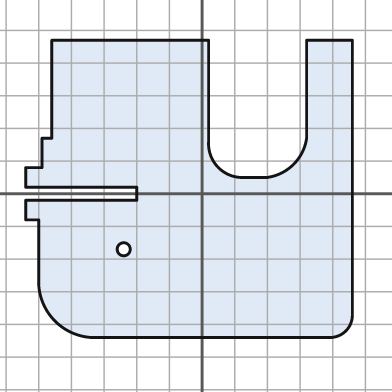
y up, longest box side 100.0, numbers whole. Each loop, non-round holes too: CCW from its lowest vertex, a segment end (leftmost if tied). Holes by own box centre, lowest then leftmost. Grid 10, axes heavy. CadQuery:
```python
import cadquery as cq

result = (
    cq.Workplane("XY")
    .moveTo(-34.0, -44.0)
    .lineTo(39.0, -44.0)
    .threePointArc((44.0, -42.0), (46.0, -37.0))
    .lineTo(46.0, 47.0)
    .lineTo(32.0, 47.0)
    .lineTo(32.0, 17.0)
    .threePointArc((28.0, 9.0), (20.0, 5.0))
    .lineTo(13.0, 5.0)
    .threePointArc((5.0, 8.0), (2.0, 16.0))
    .lineTo(2.0, 47.0)
    .lineTo(-46.0, 47.0)
    .lineTo(-46.0, 17.0)
    .lineTo(-49.0, 17.0)
    .lineTo(-49.0, 8.0)
    .lineTo(-54.0, 8.0)
    .lineTo(-54.0, 2.0)
    .lineTo(-20.0, 2.0)
    .lineTo(-20.0, -2.0)
    .lineTo(-54.0, -2.0)
    .lineTo(-54.0, -8.0)
    .lineTo(-50.0, -8.0)
    .lineTo(-50.0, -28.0)
    .threePointArc((-45.0, -39.0), (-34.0, -44.0))
    .close()
    .moveTo(-24.0, -17.0)
    .circle(2.0)
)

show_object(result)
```